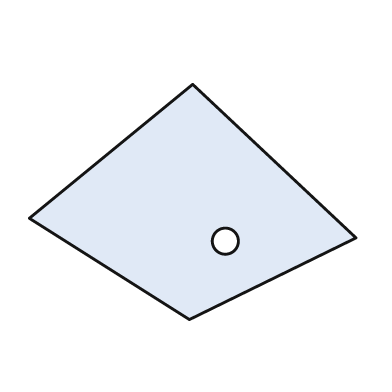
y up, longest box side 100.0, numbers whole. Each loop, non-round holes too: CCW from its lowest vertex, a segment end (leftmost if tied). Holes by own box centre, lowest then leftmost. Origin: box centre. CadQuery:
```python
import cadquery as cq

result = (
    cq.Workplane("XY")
    .moveTo(-1.0, -36.0)
    .lineTo(50.0, -11.0)
    .lineTo(0.0, 36.0)
    .lineTo(-50.0, -5.0)
    .close()
    .moveTo(10.0, -12.0)
    .circle(4.0)
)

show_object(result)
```